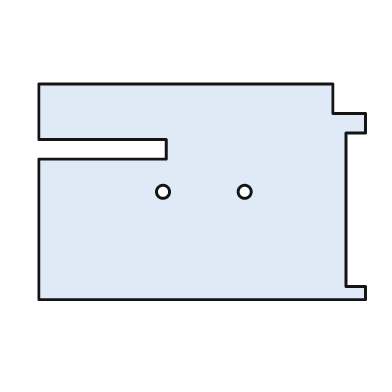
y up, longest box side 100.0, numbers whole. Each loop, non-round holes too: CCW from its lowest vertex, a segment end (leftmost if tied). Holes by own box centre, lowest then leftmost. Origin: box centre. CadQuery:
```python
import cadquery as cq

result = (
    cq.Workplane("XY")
    .moveTo(-50.0, -33.0)
    .lineTo(50.0, -33.0)
    .lineTo(50.0, -29.0)
    .lineTo(44.0, -29.0)
    .lineTo(44.0, 18.0)
    .lineTo(50.0, 18.0)
    .lineTo(50.0, 24.0)
    .lineTo(40.0, 24.0)
    .lineTo(40.0, 33.0)
    .lineTo(-50.0, 33.0)
    .lineTo(-50.0, 16.0)
    .lineTo(-11.0, 16.0)
    .lineTo(-11.0, 10.0)
    .lineTo(-50.0, 10.0)
    .close()
    .moveTo(-12.0, 0.0)
    .circle(2.0)
    .moveTo(13.0, 0.0)
    .circle(2.0)
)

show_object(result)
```